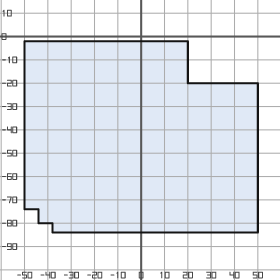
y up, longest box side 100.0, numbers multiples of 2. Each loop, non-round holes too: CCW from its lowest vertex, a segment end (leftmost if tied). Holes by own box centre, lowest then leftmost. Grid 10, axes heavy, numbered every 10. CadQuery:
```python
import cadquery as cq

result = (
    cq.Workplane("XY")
    .moveTo(-38.0, -84.0)
    .lineTo(50.0, -84.0)
    .lineTo(50.0, -20.0)
    .lineTo(20.0, -20.0)
    .lineTo(20.0, -2.0)
    .lineTo(-50.0, -2.0)
    .lineTo(-50.0, -74.0)
    .lineTo(-44.0, -74.0)
    .lineTo(-44.0, -80.0)
    .lineTo(-38.0, -80.0)
    .close()
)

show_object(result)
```